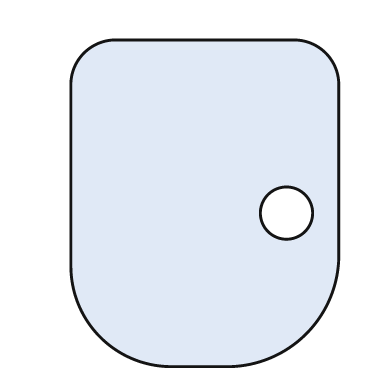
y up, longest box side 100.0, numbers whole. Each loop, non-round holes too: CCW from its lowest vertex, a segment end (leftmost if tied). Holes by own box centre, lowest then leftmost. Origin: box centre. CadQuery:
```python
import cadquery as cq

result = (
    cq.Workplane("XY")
    .moveTo(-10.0, -50.0)
    .lineTo(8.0, -50.0)
    .threePointArc((31.0, -40.0), (41.0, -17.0))
    .lineTo(41.0, 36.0)
    .threePointArc((37.0, 46.0), (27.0, 50.0))
    .lineTo(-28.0, 50.0)
    .threePointArc((-37.0, 46.0), (-41.0, 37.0))
    .lineTo(-41.0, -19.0)
    .threePointArc((-32.0, -41.0), (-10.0, -50.0))
    .close()
    .moveTo(25.0, -3.0)
    .circle(8.0)
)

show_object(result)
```